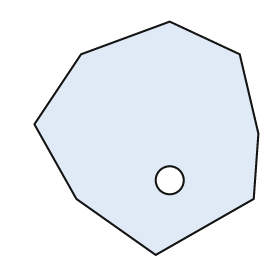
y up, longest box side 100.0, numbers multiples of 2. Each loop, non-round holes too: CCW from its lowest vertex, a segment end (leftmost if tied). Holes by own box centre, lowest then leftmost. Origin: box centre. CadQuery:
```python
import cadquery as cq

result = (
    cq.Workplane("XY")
    .moveTo(4.0, -50.0)
    .lineTo(46.0, -26.0)
    .lineTo(48.0, 2.0)
    .lineTo(40.0, 36.0)
    .lineTo(10.0, 50.0)
    .lineTo(-28.0, 36.0)
    .lineTo(-48.0, 6.0)
    .lineTo(-30.0, -26.0)
    .close()
    .moveTo(10.0, -18.0)
    .circle(6.0)
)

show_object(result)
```